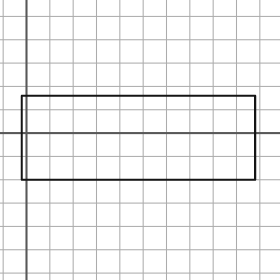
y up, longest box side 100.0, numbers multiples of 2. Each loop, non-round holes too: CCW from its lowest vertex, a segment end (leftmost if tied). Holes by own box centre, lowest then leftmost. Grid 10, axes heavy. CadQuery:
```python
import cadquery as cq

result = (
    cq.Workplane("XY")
    .moveTo(-2.0, -20.0)
    .lineTo(98.0, -20.0)
    .lineTo(98.0, 16.0)
    .lineTo(-2.0, 16.0)
    .close()
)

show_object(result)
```